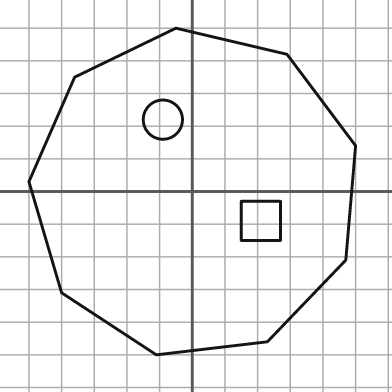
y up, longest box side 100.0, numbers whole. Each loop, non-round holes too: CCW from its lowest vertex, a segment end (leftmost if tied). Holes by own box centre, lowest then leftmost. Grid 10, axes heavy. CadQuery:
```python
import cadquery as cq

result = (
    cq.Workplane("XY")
    .moveTo(-11.0, -50.0)
    .lineTo(23.0, -46.0)
    .lineTo(47.0, -21.0)
    .lineTo(50.0, 14.0)
    .lineTo(29.0, 42.0)
    .lineTo(-5.0, 50.0)
    .lineTo(-36.0, 35.0)
    .lineTo(-50.0, 3.0)
    .lineTo(-40.0, -31.0)
    .close()
    .moveTo(15.0, -15.0)
    .lineTo(27.0, -15.0)
    .lineTo(27.0, -3.0)
    .lineTo(15.0, -3.0)
    .close()
    .moveTo(-9.0, 22.0)
    .circle(6.0)
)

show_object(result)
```